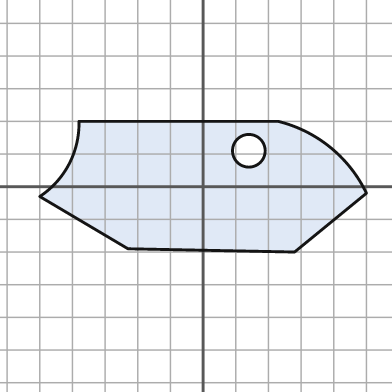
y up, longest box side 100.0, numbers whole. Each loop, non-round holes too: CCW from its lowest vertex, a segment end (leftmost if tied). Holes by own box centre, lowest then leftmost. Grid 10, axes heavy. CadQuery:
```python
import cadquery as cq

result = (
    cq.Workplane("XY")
    .moveTo(28.0, -20.0)
    .lineTo(50.0, -2.0)
    .threePointArc((39.0, 12.0), (23.0, 20.0))
    .lineTo(-38.0, 20.0)
    .threePointArc((-41.0, 7.0), (-50.0, -3.0))
    .lineTo(-23.0, -19.0)
    .close()
    .moveTo(14.0, 11.0)
    .circle(5.0)
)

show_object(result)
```